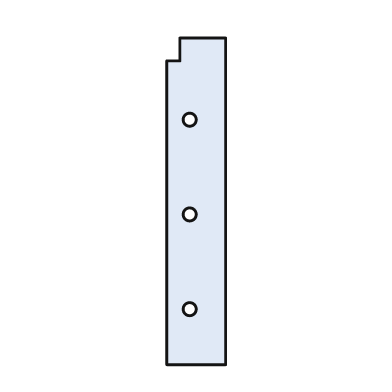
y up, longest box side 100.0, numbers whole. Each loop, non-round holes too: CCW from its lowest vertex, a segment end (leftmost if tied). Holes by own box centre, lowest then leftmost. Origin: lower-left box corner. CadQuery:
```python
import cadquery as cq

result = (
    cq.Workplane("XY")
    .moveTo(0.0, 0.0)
    .lineTo(18.0, 0.0)
    .lineTo(18.0, 100.0)
    .lineTo(4.0, 100.0)
    .lineTo(4.0, 93.0)
    .lineTo(0.0, 93.0)
    .close()
    .moveTo(7.0, 17.0)
    .circle(2.0)
    .moveTo(7.0, 46.0)
    .circle(2.0)
    .moveTo(7.0, 75.0)
    .circle(2.0)
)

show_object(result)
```